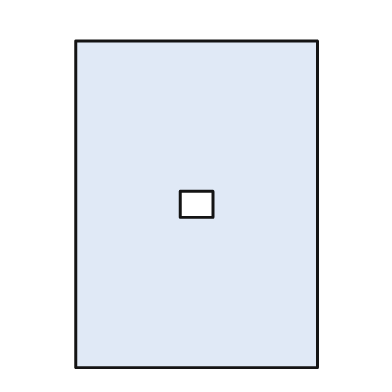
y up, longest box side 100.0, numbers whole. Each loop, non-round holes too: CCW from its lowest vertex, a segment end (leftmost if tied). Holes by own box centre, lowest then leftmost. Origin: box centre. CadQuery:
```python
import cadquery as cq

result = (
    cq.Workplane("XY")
    .moveTo(-37.0, -50.0)
    .lineTo(37.0, -50.0)
    .lineTo(37.0, 50.0)
    .lineTo(-37.0, 50.0)
    .close()
    .moveTo(-5.0, -4.0)
    .lineTo(5.0, -4.0)
    .lineTo(5.0, 4.0)
    .lineTo(-5.0, 4.0)
    .close()
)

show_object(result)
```